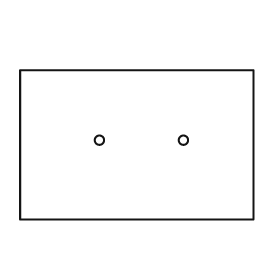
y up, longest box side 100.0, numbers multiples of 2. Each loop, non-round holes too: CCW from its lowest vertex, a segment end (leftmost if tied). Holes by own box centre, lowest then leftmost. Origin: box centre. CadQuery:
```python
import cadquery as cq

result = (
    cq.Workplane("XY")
    .moveTo(-50.0, -32.0)
    .lineTo(50.0, -32.0)
    .lineTo(50.0, 32.0)
    .lineTo(-50.0, 32.0)
    .close()
    .moveTo(-16.0, 2.0)
    .circle(2.0)
    .moveTo(20.0, 2.0)
    .circle(2.0)
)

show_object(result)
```